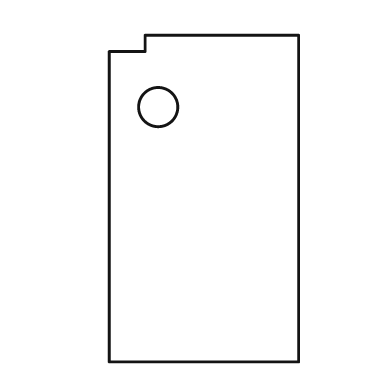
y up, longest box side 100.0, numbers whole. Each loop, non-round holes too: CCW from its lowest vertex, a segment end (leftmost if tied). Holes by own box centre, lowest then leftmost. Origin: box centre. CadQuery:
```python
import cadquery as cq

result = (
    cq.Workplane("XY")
    .moveTo(-29.0, -50.0)
    .lineTo(29.0, -50.0)
    .lineTo(29.0, 50.0)
    .lineTo(-18.0, 50.0)
    .lineTo(-18.0, 45.0)
    .lineTo(-29.0, 45.0)
    .close()
    .moveTo(-14.0, 28.0)
    .circle(6.0)
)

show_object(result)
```